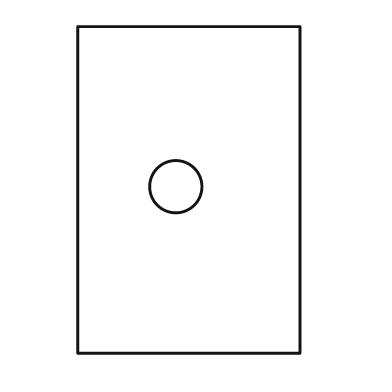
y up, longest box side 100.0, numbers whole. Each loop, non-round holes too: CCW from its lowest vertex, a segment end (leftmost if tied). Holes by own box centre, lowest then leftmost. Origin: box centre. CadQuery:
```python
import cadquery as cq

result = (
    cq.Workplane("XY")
    .moveTo(-34.0, -50.0)
    .lineTo(34.0, -50.0)
    .lineTo(34.0, 50.0)
    .lineTo(-34.0, 50.0)
    .close()
    .moveTo(-4.0, 1.0)
    .circle(8.0)
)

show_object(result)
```